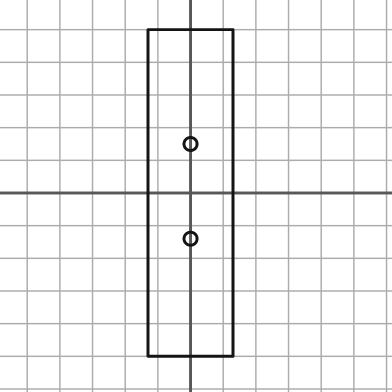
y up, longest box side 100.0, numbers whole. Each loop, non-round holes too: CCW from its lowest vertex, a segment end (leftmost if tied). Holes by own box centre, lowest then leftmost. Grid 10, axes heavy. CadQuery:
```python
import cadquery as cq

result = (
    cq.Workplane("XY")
    .moveTo(-13.0, -50.0)
    .lineTo(13.0, -50.0)
    .lineTo(13.0, 50.0)
    .lineTo(-13.0, 50.0)
    .close()
    .moveTo(0.0, -14.0)
    .circle(2.0)
    .moveTo(0.0, 15.0)
    .circle(2.0)
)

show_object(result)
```